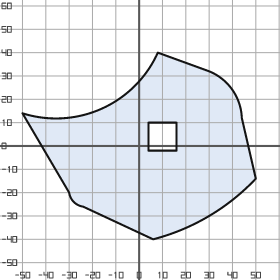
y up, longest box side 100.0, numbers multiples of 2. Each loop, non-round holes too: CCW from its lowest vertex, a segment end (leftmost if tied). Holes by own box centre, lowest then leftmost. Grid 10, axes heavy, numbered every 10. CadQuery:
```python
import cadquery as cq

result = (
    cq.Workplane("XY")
    .moveTo(6.0, -40.0)
    .threePointArc((30.0, -30.0), (50.0, -14.0))
    .lineTo(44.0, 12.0)
    .threePointArc((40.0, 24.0), (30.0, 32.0))
    .lineTo(8.0, 40.0)
    .threePointArc((-16.0, 16.0), (-50.0, 14.0))
    .lineTo(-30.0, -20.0)
    .threePointArc((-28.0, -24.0), (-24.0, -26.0))
    .close()
    .moveTo(4.0, -2.0)
    .lineTo(16.0, -2.0)
    .lineTo(16.0, 10.0)
    .lineTo(4.0, 10.0)
    .close()
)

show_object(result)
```